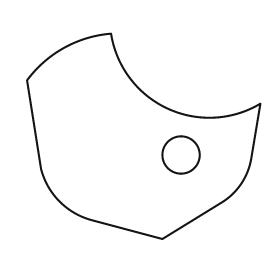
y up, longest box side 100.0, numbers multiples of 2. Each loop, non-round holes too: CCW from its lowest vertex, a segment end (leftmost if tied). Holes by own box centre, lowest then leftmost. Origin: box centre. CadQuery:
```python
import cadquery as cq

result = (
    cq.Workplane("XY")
    .moveTo(8.0, -44.0)
    .lineTo(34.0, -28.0)
    .threePointArc((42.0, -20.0), (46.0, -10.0))
    .lineTo(50.0, 14.0)
    .threePointArc((10.0, 12.0), (-14.0, 44.0))
    .threePointArc((-34.0, 38.0), (-50.0, 24.0))
    .lineTo(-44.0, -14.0)
    .threePointArc((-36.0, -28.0), (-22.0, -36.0))
    .close()
    .moveTo(16.0, -8.0)
    .circle(8.0)
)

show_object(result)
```